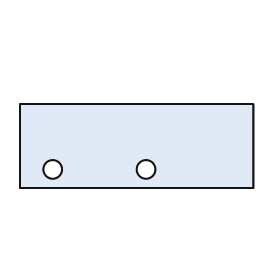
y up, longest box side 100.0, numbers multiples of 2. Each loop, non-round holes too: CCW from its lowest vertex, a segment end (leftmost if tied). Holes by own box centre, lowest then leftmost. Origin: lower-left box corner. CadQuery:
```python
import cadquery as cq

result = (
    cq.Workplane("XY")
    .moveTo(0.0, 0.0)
    .lineTo(100.0, 0.0)
    .lineTo(100.0, 36.0)
    .lineTo(0.0, 36.0)
    .close()
    .moveTo(14.0, 8.0)
    .circle(4.0)
    .moveTo(54.0, 8.0)
    .circle(4.0)
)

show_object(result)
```